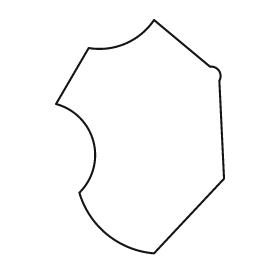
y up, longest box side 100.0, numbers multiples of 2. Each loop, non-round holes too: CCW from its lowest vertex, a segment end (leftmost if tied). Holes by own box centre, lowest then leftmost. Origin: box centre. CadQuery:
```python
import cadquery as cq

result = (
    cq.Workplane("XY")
    .moveTo(6.0, -50.0)
    .lineTo(36.0, -18.0)
    .lineTo(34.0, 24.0)
    .threePointArc((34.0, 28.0), (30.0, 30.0))
    .lineTo(6.0, 50.0)
    .threePointArc((-6.0, 40.0), (-22.0, 38.0))
    .lineTo(-36.0, 14.0)
    .threePointArc((-20.0, -2.0), (-26.0, -24.0))
    .threePointArc((-14.0, -42.0), (6.0, -50.0))
    .close()
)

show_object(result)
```